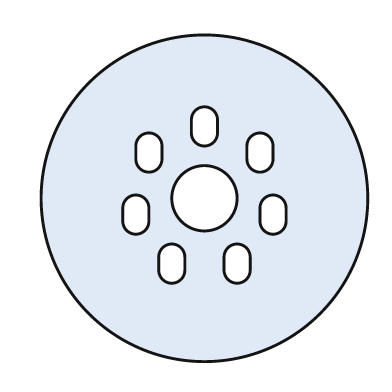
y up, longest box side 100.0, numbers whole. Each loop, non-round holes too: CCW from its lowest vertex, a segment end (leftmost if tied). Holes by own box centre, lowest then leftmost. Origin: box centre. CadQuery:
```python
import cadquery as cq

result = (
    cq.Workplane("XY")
    .moveTo(0.0, 0.0)
    .circle(50.0)
    .moveTo(-14.0, -22.0)
    .threePointArc((-10.0, -26.0), (-6.0, -22.0))
    .lineTo(-6.0, -18.0)
    .threePointArc((-10.0, -14.0), (-14.0, -18.0))
    .close()
    .moveTo(6.0, -22.0)
    .threePointArc((10.0, -26.0), (14.0, -22.0))
    .lineTo(14.0, -18.0)
    .threePointArc((10.0, -14.0), (6.0, -18.0))
    .close()
    .moveTo(-25.0, -7.0)
    .threePointArc((-21.0, -11.0), (-17.0, -7.0))
    .lineTo(-17.0, -3.0)
    .threePointArc((-21.0, 1.0), (-25.0, -3.0))
    .close()
    .moveTo(17.0, -7.0)
    .threePointArc((21.0, -11.0), (25.0, -7.0))
    .lineTo(25.0, -3.0)
    .threePointArc((21.0, 1.0), (17.0, -3.0))
    .close()
    .moveTo(0.0, 0.0)
    .circle(10.0)
    .moveTo(-21.0, 12.0)
    .threePointArc((-17.0, 8.0), (-13.0, 12.0))
    .lineTo(-13.0, 16.0)
    .threePointArc((-17.0, 20.0), (-21.0, 16.0))
    .close()
    .moveTo(13.0, 12.0)
    .threePointArc((17.0, 8.0), (21.0, 12.0))
    .lineTo(21.0, 16.0)
    .threePointArc((17.0, 20.0), (13.0, 16.0))
    .close()
    .moveTo(-4.0, 20.0)
    .threePointArc((0.0, 16.0), (4.0, 20.0))
    .lineTo(4.0, 24.0)
    .threePointArc((0.0, 28.0), (-4.0, 24.0))
    .close()
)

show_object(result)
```